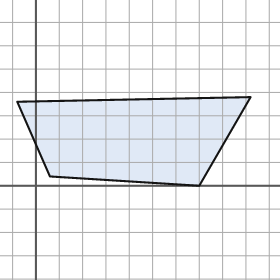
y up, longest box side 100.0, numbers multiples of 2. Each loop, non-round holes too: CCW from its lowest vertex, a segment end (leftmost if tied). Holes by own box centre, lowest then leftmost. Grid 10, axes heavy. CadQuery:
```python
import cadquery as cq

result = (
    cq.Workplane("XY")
    .moveTo(70.0, 0.0)
    .lineTo(92.0, 38.0)
    .lineTo(-8.0, 36.0)
    .lineTo(6.0, 4.0)
    .close()
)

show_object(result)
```